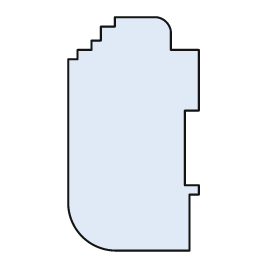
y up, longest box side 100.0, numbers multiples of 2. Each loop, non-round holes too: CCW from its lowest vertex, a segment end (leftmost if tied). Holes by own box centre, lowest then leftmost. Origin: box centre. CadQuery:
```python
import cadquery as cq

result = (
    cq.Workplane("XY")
    .moveTo(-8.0, -50.0)
    .lineTo(24.0, -50.0)
    .lineTo(24.0, -26.0)
    .lineTo(28.0, -26.0)
    .lineTo(28.0, -22.0)
    .lineTo(22.0, -22.0)
    .lineTo(22.0, 10.0)
    .lineTo(28.0, 10.0)
    .lineTo(28.0, 36.0)
    .lineTo(16.0, 36.0)
    .lineTo(16.0, 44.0)
    .threePointArc((14.0, 48.0), (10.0, 50.0))
    .lineTo(-8.0, 50.0)
    .lineTo(-8.0, 46.0)
    .lineTo(-14.0, 46.0)
    .lineTo(-14.0, 40.0)
    .lineTo(-18.0, 40.0)
    .lineTo(-18.0, 36.0)
    .lineTo(-24.0, 36.0)
    .lineTo(-24.0, 32.0)
    .lineTo(-28.0, 32.0)
    .lineTo(-28.0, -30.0)
    .threePointArc((-22.0, -44.0), (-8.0, -50.0))
    .close()
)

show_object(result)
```